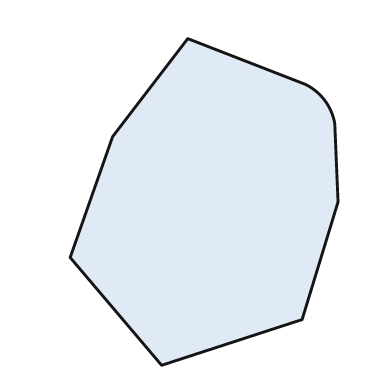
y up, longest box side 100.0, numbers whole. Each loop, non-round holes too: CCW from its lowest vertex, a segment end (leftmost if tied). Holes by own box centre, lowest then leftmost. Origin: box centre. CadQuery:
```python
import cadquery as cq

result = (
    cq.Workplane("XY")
    .moveTo(-13.0, -50.0)
    .lineTo(30.0, -36.0)
    .lineTo(41.0, 0.0)
    .lineTo(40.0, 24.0)
    .threePointArc((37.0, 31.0), (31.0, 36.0))
    .lineTo(-5.0, 50.0)
    .lineTo(-28.0, 20.0)
    .lineTo(-41.0, -17.0)
    .close()
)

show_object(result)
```